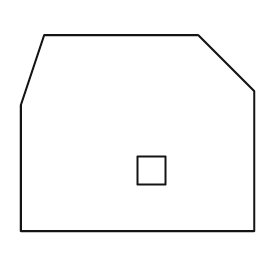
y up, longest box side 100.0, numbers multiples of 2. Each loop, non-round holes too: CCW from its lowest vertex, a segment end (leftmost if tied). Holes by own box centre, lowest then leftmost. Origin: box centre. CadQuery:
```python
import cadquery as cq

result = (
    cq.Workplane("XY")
    .moveTo(-50.0, -42.0)
    .lineTo(50.0, -42.0)
    .lineTo(50.0, 18.0)
    .lineTo(26.0, 42.0)
    .lineTo(-40.0, 42.0)
    .lineTo(-50.0, 12.0)
    .close()
    .moveTo(0.0, -22.0)
    .lineTo(12.0, -22.0)
    .lineTo(12.0, -10.0)
    .lineTo(0.0, -10.0)
    .close()
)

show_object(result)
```